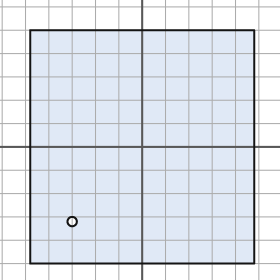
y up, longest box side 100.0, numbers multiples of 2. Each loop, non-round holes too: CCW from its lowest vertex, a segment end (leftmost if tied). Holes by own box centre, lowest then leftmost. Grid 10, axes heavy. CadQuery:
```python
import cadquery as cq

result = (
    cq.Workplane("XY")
    .moveTo(-48.0, -50.0)
    .lineTo(48.0, -50.0)
    .lineTo(48.0, 50.0)
    .lineTo(-48.0, 50.0)
    .close()
    .moveTo(-30.0, -32.0)
    .circle(2.0)
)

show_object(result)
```